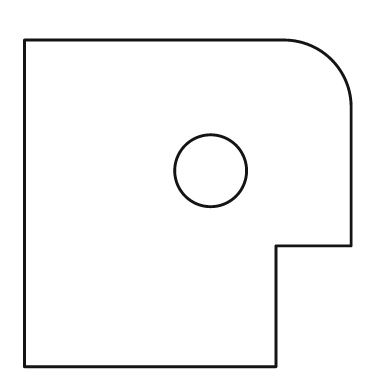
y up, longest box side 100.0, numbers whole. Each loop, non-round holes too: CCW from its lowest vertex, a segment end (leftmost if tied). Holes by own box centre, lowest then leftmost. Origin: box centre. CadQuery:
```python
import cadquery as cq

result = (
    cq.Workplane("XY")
    .moveTo(-50.0, -50.0)
    .lineTo(27.0, -50.0)
    .lineTo(27.0, -13.0)
    .lineTo(50.0, -13.0)
    .lineTo(50.0, 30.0)
    .threePointArc((44.0, 44.0), (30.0, 50.0))
    .lineTo(-50.0, 50.0)
    .close()
    .moveTo(7.0, 10.0)
    .circle(11.0)
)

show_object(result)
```